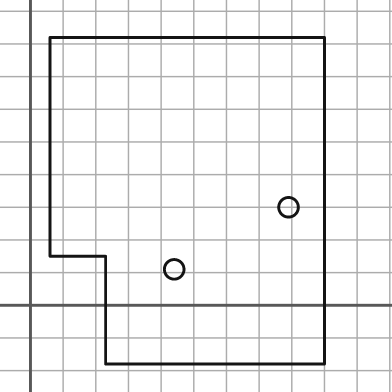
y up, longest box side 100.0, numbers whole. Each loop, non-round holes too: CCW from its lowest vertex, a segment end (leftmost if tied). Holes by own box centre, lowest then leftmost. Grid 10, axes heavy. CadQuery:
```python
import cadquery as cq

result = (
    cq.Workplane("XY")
    .moveTo(23.0, -18.0)
    .lineTo(90.0, -18.0)
    .lineTo(90.0, 82.0)
    .lineTo(6.0, 82.0)
    .lineTo(6.0, 15.0)
    .lineTo(23.0, 15.0)
    .close()
    .moveTo(44.0, 11.0)
    .circle(3.0)
    .moveTo(79.0, 30.0)
    .circle(3.0)
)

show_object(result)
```